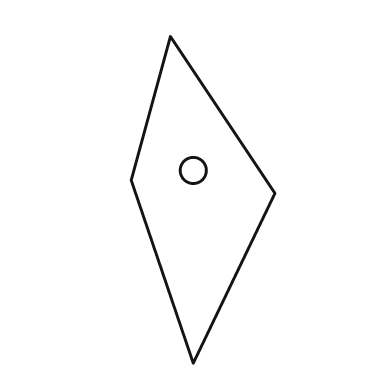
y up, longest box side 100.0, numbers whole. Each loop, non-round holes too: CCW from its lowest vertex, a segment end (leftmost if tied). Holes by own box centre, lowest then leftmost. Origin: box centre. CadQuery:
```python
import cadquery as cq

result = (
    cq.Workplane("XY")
    .moveTo(-3.0, -50.0)
    .lineTo(22.0, 2.0)
    .lineTo(-10.0, 50.0)
    .lineTo(-22.0, 6.0)
    .close()
    .moveTo(-3.0, 9.0)
    .circle(4.0)
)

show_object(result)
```